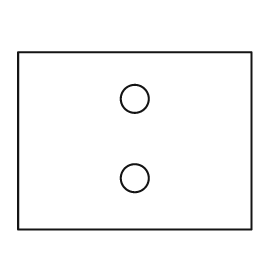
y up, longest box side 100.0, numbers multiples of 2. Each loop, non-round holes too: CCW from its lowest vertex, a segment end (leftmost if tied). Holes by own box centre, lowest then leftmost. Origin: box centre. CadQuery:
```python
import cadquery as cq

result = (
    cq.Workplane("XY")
    .moveTo(-50.0, -38.0)
    .lineTo(50.0, -38.0)
    .lineTo(50.0, 38.0)
    .lineTo(-50.0, 38.0)
    .close()
    .moveTo(0.0, -16.0)
    .circle(6.0)
    .moveTo(0.0, 18.0)
    .circle(6.0)
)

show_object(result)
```